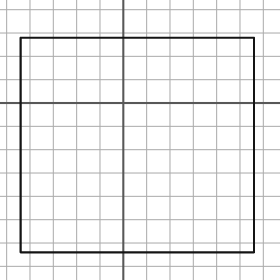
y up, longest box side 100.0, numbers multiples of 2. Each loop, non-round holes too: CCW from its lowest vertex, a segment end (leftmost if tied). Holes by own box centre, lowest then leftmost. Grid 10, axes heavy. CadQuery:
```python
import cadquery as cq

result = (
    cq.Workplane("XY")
    .moveTo(-44.0, -64.0)
    .lineTo(56.0, -64.0)
    .lineTo(56.0, 28.0)
    .lineTo(-44.0, 28.0)
    .close()
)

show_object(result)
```